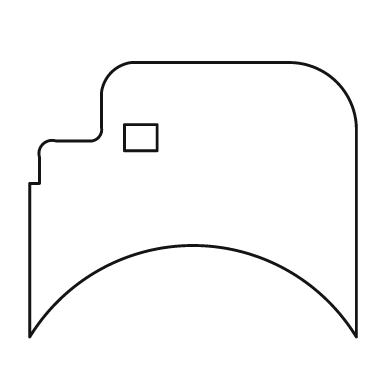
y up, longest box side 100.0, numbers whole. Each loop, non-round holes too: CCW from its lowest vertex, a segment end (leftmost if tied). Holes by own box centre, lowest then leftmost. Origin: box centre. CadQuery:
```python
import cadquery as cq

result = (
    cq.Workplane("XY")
    .moveTo(-50.0, -42.0)
    .threePointArc((0.0, -14.0), (50.0, -42.0))
    .lineTo(50.0, 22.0)
    .threePointArc((44.0, 36.0), (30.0, 42.0))
    .lineTo(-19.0, 42.0)
    .threePointArc((-25.0, 39.0), (-28.0, 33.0))
    .lineTo(-28.0, 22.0)
    .threePointArc((-29.0, 19.0), (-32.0, 18.0))
    .lineTo(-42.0, 18.0)
    .threePointArc((-46.0, 17.0), (-47.0, 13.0))
    .lineTo(-47.0, 5.0)
    .lineTo(-50.0, 5.0)
    .close()
    .moveTo(-21.0, 15.0)
    .lineTo(-11.0, 15.0)
    .lineTo(-11.0, 23.0)
    .lineTo(-21.0, 23.0)
    .close()
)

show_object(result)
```